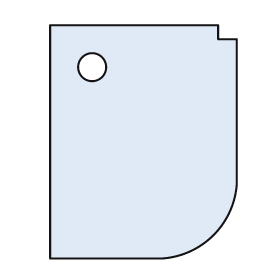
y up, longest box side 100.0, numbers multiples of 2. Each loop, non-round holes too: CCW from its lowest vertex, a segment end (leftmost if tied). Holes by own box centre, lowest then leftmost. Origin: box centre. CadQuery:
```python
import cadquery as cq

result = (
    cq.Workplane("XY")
    .moveTo(-40.0, -50.0)
    .lineTo(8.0, -50.0)
    .threePointArc((30.0, -40.0), (40.0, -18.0))
    .lineTo(40.0, 44.0)
    .lineTo(32.0, 44.0)
    .lineTo(32.0, 50.0)
    .lineTo(-40.0, 50.0)
    .close()
    .moveTo(-22.0, 32.0)
    .circle(6.0)
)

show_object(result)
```